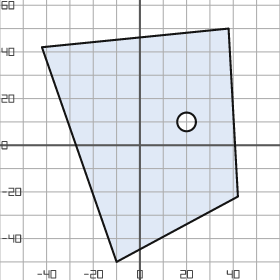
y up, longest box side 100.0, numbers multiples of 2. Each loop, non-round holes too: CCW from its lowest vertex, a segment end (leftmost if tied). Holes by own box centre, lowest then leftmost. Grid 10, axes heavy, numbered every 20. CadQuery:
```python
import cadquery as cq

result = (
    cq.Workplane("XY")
    .moveTo(-10.0, -50.0)
    .lineTo(42.0, -22.0)
    .lineTo(38.0, 50.0)
    .lineTo(-42.0, 42.0)
    .close()
    .moveTo(20.0, 10.0)
    .circle(4.0)
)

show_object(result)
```